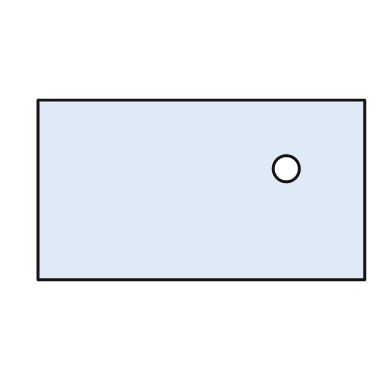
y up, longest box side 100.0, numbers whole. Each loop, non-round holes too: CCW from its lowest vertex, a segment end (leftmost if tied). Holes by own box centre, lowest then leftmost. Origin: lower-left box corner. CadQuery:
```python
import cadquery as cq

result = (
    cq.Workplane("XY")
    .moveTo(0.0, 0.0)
    .lineTo(100.0, 0.0)
    .lineTo(100.0, 55.0)
    .lineTo(0.0, 55.0)
    .close()
    .moveTo(76.0, 34.0)
    .circle(4.0)
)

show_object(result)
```